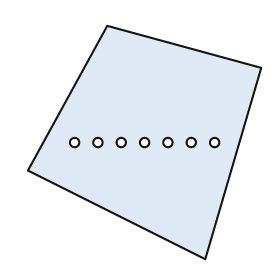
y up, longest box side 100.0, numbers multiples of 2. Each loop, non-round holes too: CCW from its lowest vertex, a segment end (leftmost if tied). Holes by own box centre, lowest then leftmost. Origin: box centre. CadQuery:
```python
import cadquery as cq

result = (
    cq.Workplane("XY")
    .moveTo(26.0, -50.0)
    .lineTo(50.0, 32.0)
    .lineTo(-16.0, 50.0)
    .lineTo(-50.0, -12.0)
    .close()
    .moveTo(-30.0, 0.0)
    .circle(2.0)
    .moveTo(-20.0, 0.0)
    .circle(2.0)
    .moveTo(-10.0, 0.0)
    .circle(2.0)
    .moveTo(0.0, 0.0)
    .circle(2.0)
    .moveTo(10.0, 0.0)
    .circle(2.0)
    .moveTo(20.0, 0.0)
    .circle(2.0)
    .moveTo(30.0, 0.0)
    .circle(2.0)
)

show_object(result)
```